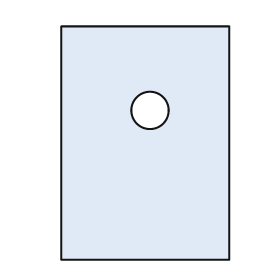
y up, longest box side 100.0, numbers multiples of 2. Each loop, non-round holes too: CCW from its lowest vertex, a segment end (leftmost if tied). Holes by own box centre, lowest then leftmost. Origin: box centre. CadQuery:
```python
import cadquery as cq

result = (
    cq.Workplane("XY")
    .moveTo(-36.0, -50.0)
    .lineTo(36.0, -50.0)
    .lineTo(36.0, 50.0)
    .lineTo(-36.0, 50.0)
    .close()
    .moveTo(2.0, 14.0)
    .circle(8.0)
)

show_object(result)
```